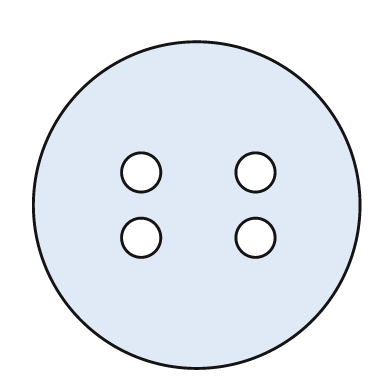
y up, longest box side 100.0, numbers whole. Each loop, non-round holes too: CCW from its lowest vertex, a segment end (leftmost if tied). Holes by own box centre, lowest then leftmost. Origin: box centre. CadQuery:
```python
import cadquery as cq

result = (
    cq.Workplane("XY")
    .moveTo(0.0, 0.0)
    .circle(50.0)
    .moveTo(-17.0, -10.0)
    .circle(6.0)
    .moveTo(18.0, -10.0)
    .circle(6.0)
    .moveTo(-17.0, 10.0)
    .circle(6.0)
    .moveTo(18.0, 10.0)
    .circle(6.0)
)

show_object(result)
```